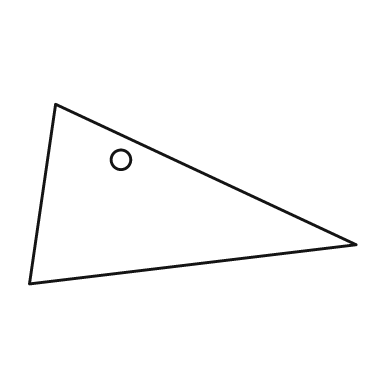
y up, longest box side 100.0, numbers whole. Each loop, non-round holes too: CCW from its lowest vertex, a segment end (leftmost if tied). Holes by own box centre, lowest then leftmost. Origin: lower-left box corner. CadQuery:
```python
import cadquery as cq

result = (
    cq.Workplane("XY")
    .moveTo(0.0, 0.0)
    .lineTo(100.0, 12.0)
    .lineTo(8.0, 55.0)
    .close()
    .moveTo(28.0, 38.0)
    .circle(3.0)
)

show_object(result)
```